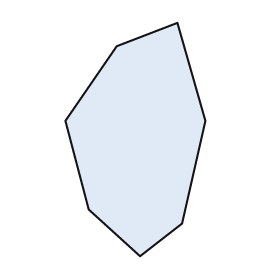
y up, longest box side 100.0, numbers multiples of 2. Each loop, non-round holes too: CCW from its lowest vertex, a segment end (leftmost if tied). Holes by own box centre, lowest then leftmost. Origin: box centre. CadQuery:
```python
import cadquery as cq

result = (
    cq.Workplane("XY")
    .moveTo(2.0, -50.0)
    .lineTo(20.0, -36.0)
    .lineTo(30.0, 8.0)
    .lineTo(18.0, 50.0)
    .lineTo(-8.0, 40.0)
    .lineTo(-30.0, 8.0)
    .lineTo(-20.0, -30.0)
    .close()
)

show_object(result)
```